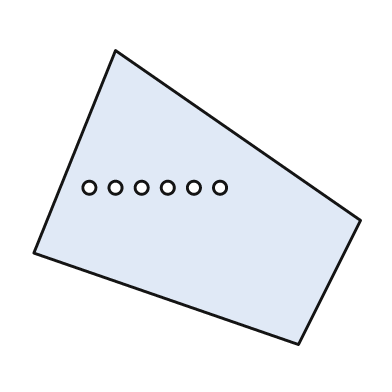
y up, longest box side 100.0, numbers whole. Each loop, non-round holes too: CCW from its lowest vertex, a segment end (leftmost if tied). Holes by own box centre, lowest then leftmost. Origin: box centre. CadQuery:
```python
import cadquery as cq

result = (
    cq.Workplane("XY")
    .moveTo(31.0, -45.0)
    .lineTo(50.0, -7.0)
    .lineTo(-25.0, 45.0)
    .lineTo(-50.0, -17.0)
    .close()
    .moveTo(-33.0, 3.0)
    .circle(2.0)
    .moveTo(-25.0, 3.0)
    .circle(2.0)
    .moveTo(-17.0, 3.0)
    .circle(2.0)
    .moveTo(-9.0, 3.0)
    .circle(2.0)
    .moveTo(-1.0, 3.0)
    .circle(2.0)
    .moveTo(7.0, 3.0)
    .circle(2.0)
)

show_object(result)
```